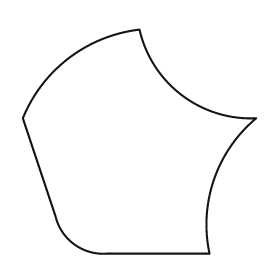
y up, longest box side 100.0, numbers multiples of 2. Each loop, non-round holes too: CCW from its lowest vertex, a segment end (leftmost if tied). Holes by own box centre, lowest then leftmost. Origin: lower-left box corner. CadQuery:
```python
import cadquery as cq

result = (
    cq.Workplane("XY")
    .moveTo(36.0, 0.0)
    .lineTo(80.0, 0.0)
    .threePointArc((82.0, 32.0), (100.0, 58.0))
    .threePointArc((68.0, 68.0), (50.0, 96.0))
    .threePointArc((20.0, 84.0), (0.0, 58.0))
    .lineTo(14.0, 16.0)
    .threePointArc((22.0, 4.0), (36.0, 0.0))
    .close()
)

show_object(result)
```